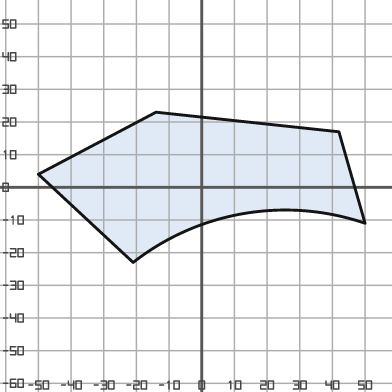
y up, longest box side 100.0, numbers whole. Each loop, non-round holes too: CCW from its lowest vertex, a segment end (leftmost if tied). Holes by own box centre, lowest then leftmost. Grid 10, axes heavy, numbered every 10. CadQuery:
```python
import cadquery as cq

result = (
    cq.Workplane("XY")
    .moveTo(-21.0, -23.0)
    .threePointArc((13.0, -8.0), (50.0, -11.0))
    .lineTo(42.0, 17.0)
    .lineTo(-14.0, 23.0)
    .lineTo(-50.0, 4.0)
    .close()
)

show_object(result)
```